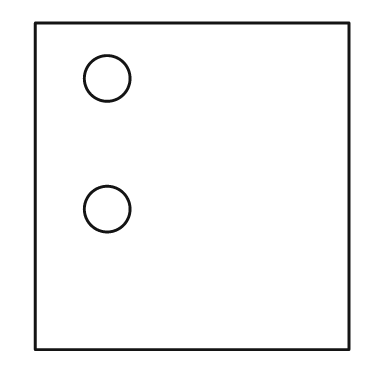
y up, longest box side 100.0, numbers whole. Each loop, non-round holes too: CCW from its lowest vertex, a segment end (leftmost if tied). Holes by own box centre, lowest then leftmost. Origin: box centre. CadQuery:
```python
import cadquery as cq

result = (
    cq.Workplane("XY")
    .moveTo(-48.0, -50.0)
    .lineTo(48.0, -50.0)
    .lineTo(48.0, 50.0)
    .lineTo(-48.0, 50.0)
    .close()
    .moveTo(-26.0, -7.0)
    .circle(7.0)
    .moveTo(-26.0, 33.0)
    .circle(7.0)
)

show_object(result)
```